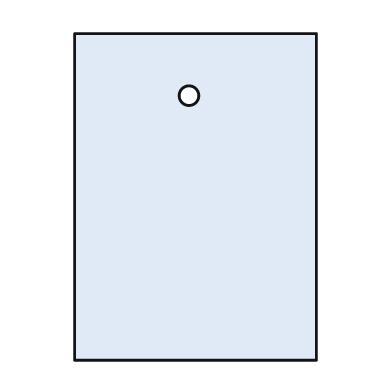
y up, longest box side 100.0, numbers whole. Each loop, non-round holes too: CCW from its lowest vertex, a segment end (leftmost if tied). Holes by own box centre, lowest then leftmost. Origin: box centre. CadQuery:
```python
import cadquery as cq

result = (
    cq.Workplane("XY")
    .moveTo(-37.0, -50.0)
    .lineTo(37.0, -50.0)
    .lineTo(37.0, 50.0)
    .lineTo(-37.0, 50.0)
    .close()
    .moveTo(-2.0, 31.0)
    .circle(3.0)
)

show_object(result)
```